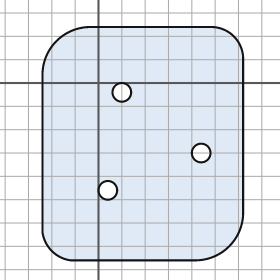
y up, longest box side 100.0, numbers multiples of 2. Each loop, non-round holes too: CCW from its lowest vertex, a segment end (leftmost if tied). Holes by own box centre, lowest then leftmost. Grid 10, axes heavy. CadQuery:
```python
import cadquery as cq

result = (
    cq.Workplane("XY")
    .moveTo(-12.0, -76.0)
    .lineTo(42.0, -76.0)
    .threePointArc((56.0, -70.0), (62.0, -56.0))
    .lineTo(62.0, 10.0)
    .threePointArc((58.0, 20.0), (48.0, 24.0))
    .lineTo(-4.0, 24.0)
    .threePointArc((-18.0, 18.0), (-24.0, 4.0))
    .lineTo(-24.0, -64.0)
    .threePointArc((-20.0, -72.0), (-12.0, -76.0))
    .close()
    .moveTo(4.0, -46.0)
    .circle(4.0)
    .moveTo(44.0, -30.0)
    .circle(4.0)
    .moveTo(10.0, -4.0)
    .circle(4.0)
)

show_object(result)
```